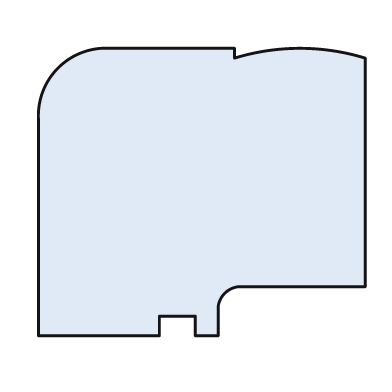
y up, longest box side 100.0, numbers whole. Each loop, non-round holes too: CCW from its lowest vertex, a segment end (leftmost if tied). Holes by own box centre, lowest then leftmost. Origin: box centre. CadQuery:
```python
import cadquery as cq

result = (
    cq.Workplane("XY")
    .moveTo(-50.0, -44.0)
    .lineTo(-13.0, -44.0)
    .lineTo(-13.0, -38.0)
    .lineTo(-2.0, -38.0)
    .lineTo(-2.0, -44.0)
    .lineTo(5.0, -44.0)
    .lineTo(5.0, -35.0)
    .threePointArc((7.0, -31.0), (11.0, -29.0))
    .lineTo(50.0, -29.0)
    .lineTo(50.0, 41.0)
    .threePointArc((30.0, 44.0), (10.0, 41.0))
    .lineTo(10.0, 44.0)
    .lineTo(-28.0, 44.0)
    .threePointArc((-44.0, 38.0), (-50.0, 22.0))
    .close()
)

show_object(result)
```